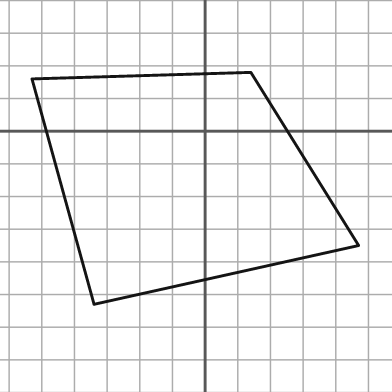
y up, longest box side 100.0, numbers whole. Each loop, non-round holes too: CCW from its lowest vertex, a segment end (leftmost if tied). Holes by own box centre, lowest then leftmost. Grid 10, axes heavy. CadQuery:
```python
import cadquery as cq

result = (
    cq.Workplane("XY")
    .moveTo(-34.0, -53.0)
    .lineTo(47.0, -35.0)
    .lineTo(14.0, 18.0)
    .lineTo(-53.0, 16.0)
    .close()
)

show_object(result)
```